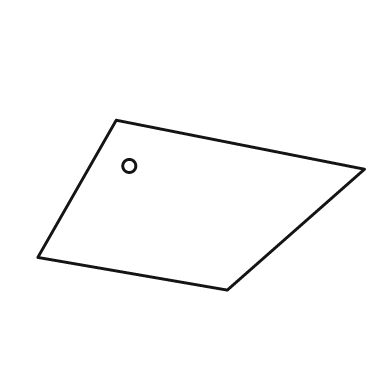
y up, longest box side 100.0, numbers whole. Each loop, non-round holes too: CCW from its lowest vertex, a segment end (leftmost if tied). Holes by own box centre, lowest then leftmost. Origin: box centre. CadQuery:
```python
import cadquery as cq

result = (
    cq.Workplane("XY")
    .moveTo(8.0, -26.0)
    .lineTo(50.0, 11.0)
    .lineTo(-26.0, 26.0)
    .lineTo(-50.0, -16.0)
    .close()
    .moveTo(-22.0, 12.0)
    .circle(2.0)
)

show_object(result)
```